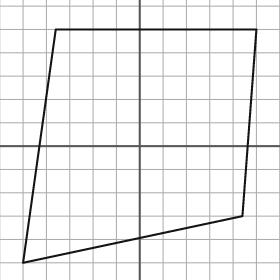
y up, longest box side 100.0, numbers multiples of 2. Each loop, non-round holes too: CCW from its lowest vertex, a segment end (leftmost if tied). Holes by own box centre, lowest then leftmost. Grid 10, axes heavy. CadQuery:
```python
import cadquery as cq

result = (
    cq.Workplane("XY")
    .moveTo(-50.0, -50.0)
    .lineTo(44.0, -30.0)
    .lineTo(50.0, 50.0)
    .lineTo(-36.0, 50.0)
    .close()
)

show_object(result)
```